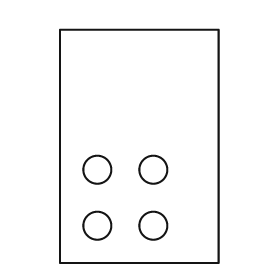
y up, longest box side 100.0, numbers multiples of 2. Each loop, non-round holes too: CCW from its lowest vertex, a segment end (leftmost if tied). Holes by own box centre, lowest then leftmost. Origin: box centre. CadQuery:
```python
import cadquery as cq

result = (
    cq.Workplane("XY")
    .moveTo(-34.0, -50.0)
    .lineTo(34.0, -50.0)
    .lineTo(34.0, 50.0)
    .lineTo(-34.0, 50.0)
    .close()
    .moveTo(-18.0, -34.0)
    .circle(6.0)
    .moveTo(6.0, -34.0)
    .circle(6.0)
    .moveTo(-18.0, -10.0)
    .circle(6.0)
    .moveTo(6.0, -10.0)
    .circle(6.0)
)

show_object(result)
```